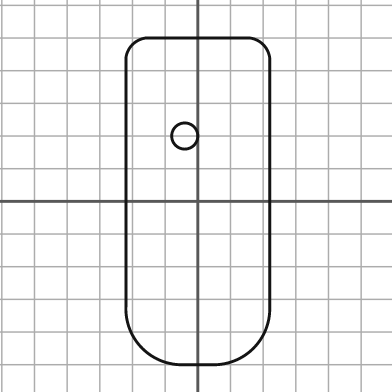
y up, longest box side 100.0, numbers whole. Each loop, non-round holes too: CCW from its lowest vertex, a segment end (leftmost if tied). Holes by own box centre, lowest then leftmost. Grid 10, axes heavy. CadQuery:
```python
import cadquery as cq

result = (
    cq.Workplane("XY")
    .moveTo(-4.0, -50.0)
    .lineTo(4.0, -50.0)
    .threePointArc((17.0, -45.0), (22.0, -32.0))
    .lineTo(22.0, 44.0)
    .threePointArc((20.0, 48.0), (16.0, 50.0))
    .lineTo(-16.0, 50.0)
    .threePointArc((-20.0, 48.0), (-22.0, 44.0))
    .lineTo(-22.0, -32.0)
    .threePointArc((-17.0, -45.0), (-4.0, -50.0))
    .close()
    .moveTo(-4.0, 20.0)
    .circle(4.0)
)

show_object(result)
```